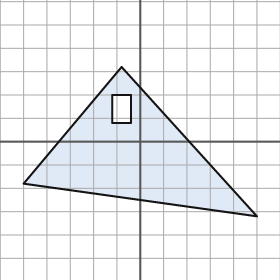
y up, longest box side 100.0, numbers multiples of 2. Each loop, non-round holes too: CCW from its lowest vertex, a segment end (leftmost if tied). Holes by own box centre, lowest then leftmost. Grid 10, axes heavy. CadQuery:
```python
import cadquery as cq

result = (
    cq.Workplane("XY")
    .moveTo(50.0, -32.0)
    .lineTo(-8.0, 32.0)
    .lineTo(-50.0, -18.0)
    .close()
    .moveTo(-12.0, 8.0)
    .lineTo(-4.0, 8.0)
    .lineTo(-4.0, 20.0)
    .lineTo(-12.0, 20.0)
    .close()
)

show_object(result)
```